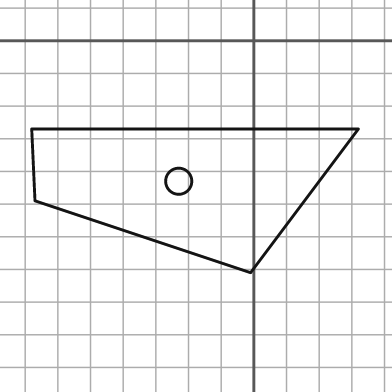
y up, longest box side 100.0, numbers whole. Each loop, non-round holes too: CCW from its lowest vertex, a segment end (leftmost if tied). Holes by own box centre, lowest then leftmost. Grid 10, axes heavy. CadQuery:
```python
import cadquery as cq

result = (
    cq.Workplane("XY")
    .moveTo(-1.0, -71.0)
    .lineTo(32.0, -27.0)
    .lineTo(-68.0, -27.0)
    .lineTo(-67.0, -49.0)
    .close()
    .moveTo(-23.0, -43.0)
    .circle(4.0)
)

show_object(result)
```